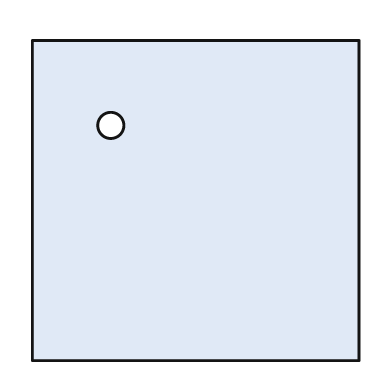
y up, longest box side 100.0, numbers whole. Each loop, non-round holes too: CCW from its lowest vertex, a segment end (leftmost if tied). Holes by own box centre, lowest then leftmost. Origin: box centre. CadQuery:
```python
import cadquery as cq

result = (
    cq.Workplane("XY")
    .moveTo(-50.0, -49.0)
    .lineTo(50.0, -49.0)
    .lineTo(50.0, 49.0)
    .lineTo(-50.0, 49.0)
    .close()
    .moveTo(-26.0, 23.0)
    .circle(4.0)
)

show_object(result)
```